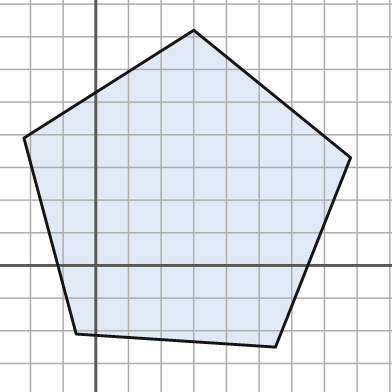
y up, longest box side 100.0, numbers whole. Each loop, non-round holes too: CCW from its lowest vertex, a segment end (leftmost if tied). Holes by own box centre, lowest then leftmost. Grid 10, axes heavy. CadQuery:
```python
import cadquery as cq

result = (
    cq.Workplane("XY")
    .moveTo(55.0, -25.0)
    .lineTo(78.0, 33.0)
    .lineTo(30.0, 72.0)
    .lineTo(-22.0, 39.0)
    .lineTo(-6.0, -21.0)
    .close()
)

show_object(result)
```